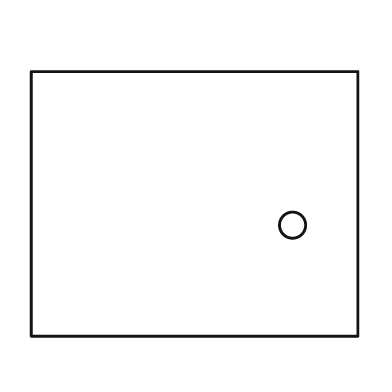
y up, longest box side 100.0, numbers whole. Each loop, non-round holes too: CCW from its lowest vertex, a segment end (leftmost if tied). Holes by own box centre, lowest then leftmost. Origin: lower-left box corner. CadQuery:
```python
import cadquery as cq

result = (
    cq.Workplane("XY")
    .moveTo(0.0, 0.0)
    .lineTo(100.0, 0.0)
    .lineTo(100.0, 81.0)
    .lineTo(0.0, 81.0)
    .close()
    .moveTo(80.0, 34.0)
    .circle(4.0)
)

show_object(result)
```